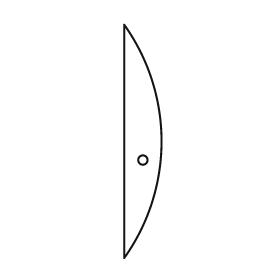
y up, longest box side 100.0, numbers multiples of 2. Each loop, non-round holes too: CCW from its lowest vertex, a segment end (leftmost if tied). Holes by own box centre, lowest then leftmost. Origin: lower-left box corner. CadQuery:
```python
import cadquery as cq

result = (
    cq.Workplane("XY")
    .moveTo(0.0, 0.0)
    .threePointArc((16.0, 50.0), (0.0, 100.0))
    .close()
    .moveTo(8.0, 42.0)
    .circle(2.0)
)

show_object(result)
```